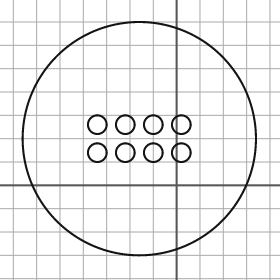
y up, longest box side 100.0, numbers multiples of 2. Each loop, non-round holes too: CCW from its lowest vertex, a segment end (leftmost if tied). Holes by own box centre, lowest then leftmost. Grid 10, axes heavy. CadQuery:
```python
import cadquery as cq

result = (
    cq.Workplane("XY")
    .moveTo(-16.0, 20.0)
    .circle(50.0)
    .moveTo(-34.0, 14.0)
    .circle(4.0)
    .moveTo(-22.0, 14.0)
    .circle(4.0)
    .moveTo(-10.0, 14.0)
    .circle(4.0)
    .moveTo(2.0, 14.0)
    .circle(4.0)
    .moveTo(-34.0, 26.0)
    .circle(4.0)
    .moveTo(-22.0, 26.0)
    .circle(4.0)
    .moveTo(-10.0, 26.0)
    .circle(4.0)
    .moveTo(2.0, 26.0)
    .circle(4.0)
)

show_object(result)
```